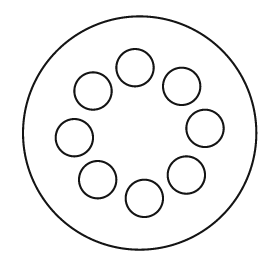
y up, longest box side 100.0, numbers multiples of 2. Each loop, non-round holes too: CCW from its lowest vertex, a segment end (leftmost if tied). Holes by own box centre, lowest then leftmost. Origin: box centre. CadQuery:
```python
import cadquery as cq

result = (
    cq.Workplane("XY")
    .moveTo(0.0, 0.0)
    .circle(50.0)
    .moveTo(2.0, -28.0)
    .circle(8.0)
    .moveTo(-18.0, -20.0)
    .circle(8.0)
    .moveTo(20.0, -18.0)
    .circle(8.0)
    .moveTo(-28.0, -2.0)
    .circle(8.0)
    .moveTo(28.0, 2.0)
    .circle(8.0)
    .moveTo(-20.0, 18.0)
    .circle(8.0)
    .moveTo(18.0, 20.0)
    .circle(8.0)
    .moveTo(-2.0, 28.0)
    .circle(8.0)
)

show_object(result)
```